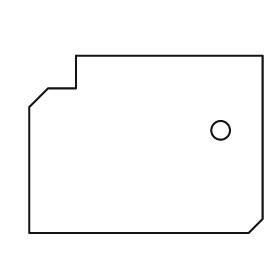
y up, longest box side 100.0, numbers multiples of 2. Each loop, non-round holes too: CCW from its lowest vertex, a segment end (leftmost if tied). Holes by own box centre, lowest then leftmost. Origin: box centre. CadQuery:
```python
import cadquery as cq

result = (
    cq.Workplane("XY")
    .moveTo(-50.0, -38.0)
    .lineTo(44.0, -38.0)
    .lineTo(50.0, -32.0)
    .lineTo(50.0, 38.0)
    .lineTo(-30.0, 38.0)
    .lineTo(-30.0, 24.0)
    .lineTo(-42.0, 24.0)
    .lineTo(-50.0, 16.0)
    .close()
    .moveTo(32.0, 6.0)
    .circle(4.0)
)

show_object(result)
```